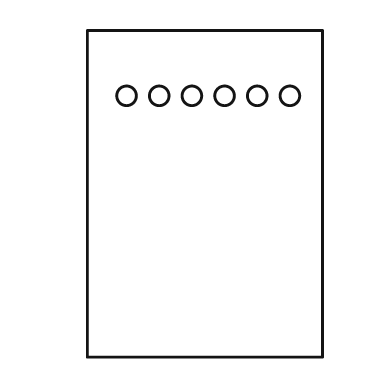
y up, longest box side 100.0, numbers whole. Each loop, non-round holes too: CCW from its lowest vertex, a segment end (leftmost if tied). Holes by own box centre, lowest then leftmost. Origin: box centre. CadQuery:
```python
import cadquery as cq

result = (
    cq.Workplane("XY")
    .moveTo(-36.0, -50.0)
    .lineTo(36.0, -50.0)
    .lineTo(36.0, 50.0)
    .lineTo(-36.0, 50.0)
    .close()
    .moveTo(-24.0, 30.0)
    .circle(3.0)
    .moveTo(-14.0, 30.0)
    .circle(3.0)
    .moveTo(-4.0, 30.0)
    .circle(3.0)
    .moveTo(6.0, 30.0)
    .circle(3.0)
    .moveTo(16.0, 30.0)
    .circle(3.0)
    .moveTo(26.0, 30.0)
    .circle(3.0)
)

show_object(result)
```